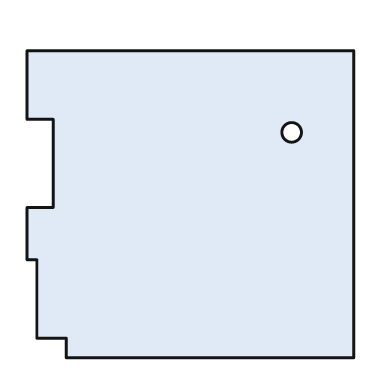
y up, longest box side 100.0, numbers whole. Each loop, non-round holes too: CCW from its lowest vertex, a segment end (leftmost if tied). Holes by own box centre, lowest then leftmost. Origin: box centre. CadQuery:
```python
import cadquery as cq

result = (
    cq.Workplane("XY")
    .moveTo(-38.0, -47.0)
    .lineTo(50.0, -47.0)
    .lineTo(50.0, 47.0)
    .lineTo(-50.0, 47.0)
    .lineTo(-50.0, 26.0)
    .lineTo(-42.0, 26.0)
    .lineTo(-42.0, -1.0)
    .lineTo(-50.0, -1.0)
    .lineTo(-50.0, -17.0)
    .lineTo(-47.0, -17.0)
    .lineTo(-47.0, -41.0)
    .lineTo(-38.0, -41.0)
    .close()
    .moveTo(31.0, 22.0)
    .circle(3.0)
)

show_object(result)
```